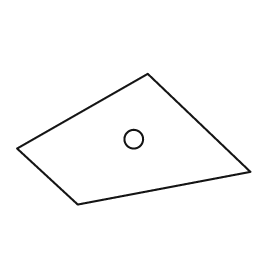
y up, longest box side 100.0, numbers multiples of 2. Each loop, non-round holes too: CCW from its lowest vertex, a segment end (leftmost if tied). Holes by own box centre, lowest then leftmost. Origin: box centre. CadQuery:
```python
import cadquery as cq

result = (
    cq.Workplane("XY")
    .moveTo(-24.0, -28.0)
    .lineTo(50.0, -14.0)
    .lineTo(6.0, 28.0)
    .lineTo(-50.0, -4.0)
    .close()
    .moveTo(0.0, 0.0)
    .circle(4.0)
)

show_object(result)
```